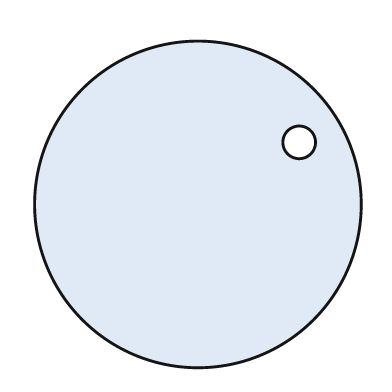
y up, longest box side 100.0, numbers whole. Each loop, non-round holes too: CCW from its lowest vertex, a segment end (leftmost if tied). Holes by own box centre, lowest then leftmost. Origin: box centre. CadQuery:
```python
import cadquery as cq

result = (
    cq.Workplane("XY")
    .moveTo(0.0, 0.0)
    .circle(50.0)
    .moveTo(31.0, 19.0)
    .circle(5.0)
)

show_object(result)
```